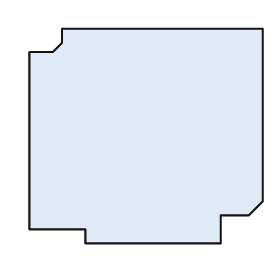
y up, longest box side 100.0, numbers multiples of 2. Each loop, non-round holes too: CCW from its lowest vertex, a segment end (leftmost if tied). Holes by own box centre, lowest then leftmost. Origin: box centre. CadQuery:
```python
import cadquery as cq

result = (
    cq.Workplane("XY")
    .moveTo(-26.0, -46.0)
    .lineTo(32.0, -46.0)
    .lineTo(32.0, -34.0)
    .lineTo(44.0, -34.0)
    .lineTo(50.0, -28.0)
    .lineTo(50.0, 46.0)
    .lineTo(-36.0, 46.0)
    .lineTo(-36.0, 40.0)
    .lineTo(-40.0, 36.0)
    .lineTo(-50.0, 36.0)
    .lineTo(-50.0, -40.0)
    .lineTo(-26.0, -40.0)
    .close()
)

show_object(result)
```